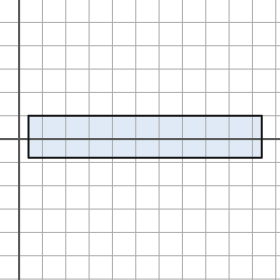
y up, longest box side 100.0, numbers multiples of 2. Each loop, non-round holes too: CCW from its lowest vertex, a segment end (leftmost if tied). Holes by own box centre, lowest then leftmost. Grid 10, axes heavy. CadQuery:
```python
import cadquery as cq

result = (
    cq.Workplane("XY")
    .moveTo(4.0, -8.0)
    .lineTo(104.0, -8.0)
    .lineTo(104.0, 10.0)
    .lineTo(4.0, 10.0)
    .close()
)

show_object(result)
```